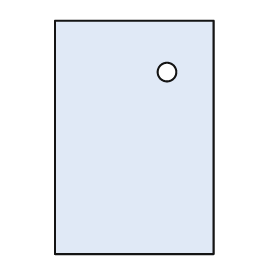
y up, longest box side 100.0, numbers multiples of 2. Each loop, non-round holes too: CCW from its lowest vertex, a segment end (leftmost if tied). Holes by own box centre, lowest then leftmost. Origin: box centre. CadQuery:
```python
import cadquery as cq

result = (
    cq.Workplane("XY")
    .moveTo(-34.0, -50.0)
    .lineTo(34.0, -50.0)
    .lineTo(34.0, 50.0)
    .lineTo(-34.0, 50.0)
    .close()
    .moveTo(14.0, 28.0)
    .circle(4.0)
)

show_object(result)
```